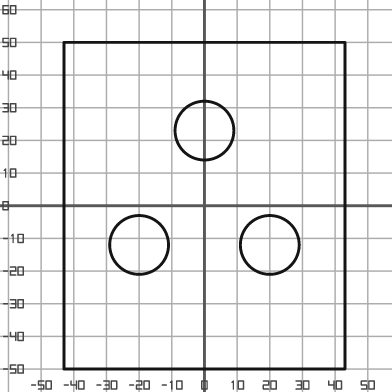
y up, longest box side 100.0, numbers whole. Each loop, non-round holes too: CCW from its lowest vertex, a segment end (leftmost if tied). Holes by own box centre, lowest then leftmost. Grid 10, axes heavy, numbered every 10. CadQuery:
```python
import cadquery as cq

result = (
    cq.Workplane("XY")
    .moveTo(-43.0, -50.0)
    .lineTo(43.0, -50.0)
    .lineTo(43.0, 50.0)
    .lineTo(-43.0, 50.0)
    .close()
    .moveTo(-20.0, -12.0)
    .circle(9.0)
    .moveTo(20.0, -12.0)
    .circle(9.0)
    .moveTo(0.0, 23.0)
    .circle(9.0)
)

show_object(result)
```